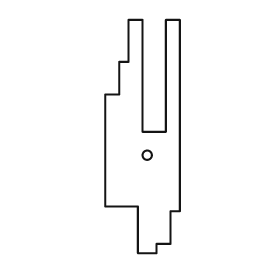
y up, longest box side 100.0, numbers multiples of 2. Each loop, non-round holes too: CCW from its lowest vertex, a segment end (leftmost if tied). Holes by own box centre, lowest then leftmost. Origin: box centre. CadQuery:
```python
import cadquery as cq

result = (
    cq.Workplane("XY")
    .moveTo(-2.0, -50.0)
    .lineTo(6.0, -50.0)
    .lineTo(6.0, -46.0)
    .lineTo(12.0, -46.0)
    .lineTo(12.0, -32.0)
    .lineTo(16.0, -32.0)
    .lineTo(16.0, 50.0)
    .lineTo(10.0, 50.0)
    .lineTo(10.0, 2.0)
    .lineTo(0.0, 2.0)
    .lineTo(0.0, 50.0)
    .lineTo(-6.0, 50.0)
    .lineTo(-6.0, 32.0)
    .lineTo(-10.0, 32.0)
    .lineTo(-10.0, 18.0)
    .lineTo(-16.0, 18.0)
    .lineTo(-16.0, -30.0)
    .lineTo(-2.0, -30.0)
    .close()
    .moveTo(2.0, -8.0)
    .circle(2.0)
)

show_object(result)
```